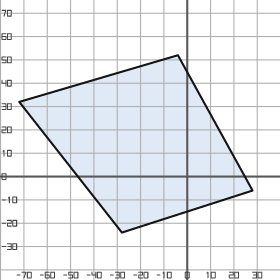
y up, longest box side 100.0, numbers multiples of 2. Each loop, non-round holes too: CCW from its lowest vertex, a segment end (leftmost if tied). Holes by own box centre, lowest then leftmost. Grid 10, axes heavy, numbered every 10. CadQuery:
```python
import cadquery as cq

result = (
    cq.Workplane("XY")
    .moveTo(-28.0, -24.0)
    .lineTo(28.0, -6.0)
    .lineTo(-4.0, 52.0)
    .lineTo(-72.0, 32.0)
    .close()
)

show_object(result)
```